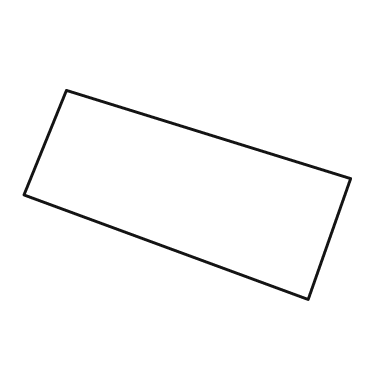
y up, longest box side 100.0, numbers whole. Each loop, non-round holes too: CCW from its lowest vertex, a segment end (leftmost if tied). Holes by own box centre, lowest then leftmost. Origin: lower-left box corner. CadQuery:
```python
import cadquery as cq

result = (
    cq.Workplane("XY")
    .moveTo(87.0, 0.0)
    .lineTo(100.0, 37.0)
    .lineTo(13.0, 64.0)
    .lineTo(0.0, 32.0)
    .close()
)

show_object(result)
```